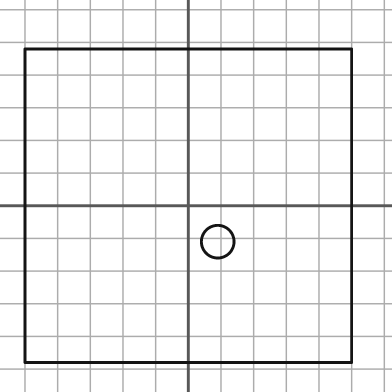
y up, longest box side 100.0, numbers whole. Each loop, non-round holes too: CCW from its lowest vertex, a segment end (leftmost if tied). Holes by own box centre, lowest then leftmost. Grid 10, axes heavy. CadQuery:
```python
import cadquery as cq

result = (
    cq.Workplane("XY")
    .moveTo(-50.0, -48.0)
    .lineTo(50.0, -48.0)
    .lineTo(50.0, 48.0)
    .lineTo(-50.0, 48.0)
    .close()
    .moveTo(9.0, -11.0)
    .circle(5.0)
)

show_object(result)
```